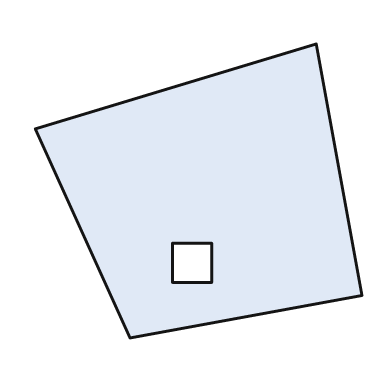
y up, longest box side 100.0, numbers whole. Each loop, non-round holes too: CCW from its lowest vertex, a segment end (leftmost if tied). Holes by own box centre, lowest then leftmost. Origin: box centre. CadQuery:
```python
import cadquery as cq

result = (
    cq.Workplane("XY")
    .moveTo(-21.0, -45.0)
    .lineTo(50.0, -32.0)
    .lineTo(36.0, 45.0)
    .lineTo(-50.0, 19.0)
    .close()
    .moveTo(-8.0, -28.0)
    .lineTo(4.0, -28.0)
    .lineTo(4.0, -16.0)
    .lineTo(-8.0, -16.0)
    .close()
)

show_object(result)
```